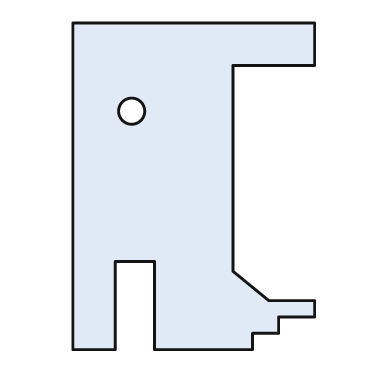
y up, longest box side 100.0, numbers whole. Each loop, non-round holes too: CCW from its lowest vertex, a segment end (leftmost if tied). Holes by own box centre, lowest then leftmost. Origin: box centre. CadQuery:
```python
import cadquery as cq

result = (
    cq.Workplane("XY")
    .moveTo(-37.0, -50.0)
    .lineTo(-24.0, -50.0)
    .lineTo(-24.0, -23.0)
    .lineTo(-12.0, -23.0)
    .lineTo(-12.0, -50.0)
    .lineTo(18.0, -50.0)
    .lineTo(18.0, -45.0)
    .lineTo(26.0, -45.0)
    .lineTo(26.0, -40.0)
    .lineTo(37.0, -40.0)
    .lineTo(37.0, -35.0)
    .lineTo(23.0, -35.0)
    .lineTo(12.0, -26.0)
    .lineTo(12.0, 37.0)
    .lineTo(37.0, 37.0)
    .lineTo(37.0, 50.0)
    .lineTo(-37.0, 50.0)
    .close()
    .moveTo(-19.0, 23.0)
    .circle(4.0)
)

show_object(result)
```